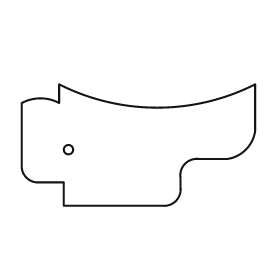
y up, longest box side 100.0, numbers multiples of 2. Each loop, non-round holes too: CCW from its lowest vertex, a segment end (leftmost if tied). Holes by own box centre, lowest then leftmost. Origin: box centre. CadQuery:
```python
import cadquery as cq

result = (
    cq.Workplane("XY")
    .moveTo(-32.0, -26.0)
    .lineTo(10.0, -26.0)
    .threePointArc((16.0, -24.0), (18.0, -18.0))
    .lineTo(18.0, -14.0)
    .threePointArc((20.0, -8.0), (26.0, -6.0))
    .lineTo(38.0, -6.0)
    .threePointArc((46.0, -2.0), (50.0, 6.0))
    .lineTo(50.0, 26.0)
    .threePointArc((8.0, 16.0), (-34.0, 26.0))
    .lineTo(-34.0, 18.0)
    .threePointArc((-42.0, 20.0), (-50.0, 18.0))
    .lineTo(-50.0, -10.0)
    .threePointArc((-48.0, -14.0), (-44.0, -16.0))
    .lineTo(-32.0, -16.0)
    .close()
    .moveTo(-30.0, -2.0)
    .circle(2.0)
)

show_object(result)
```